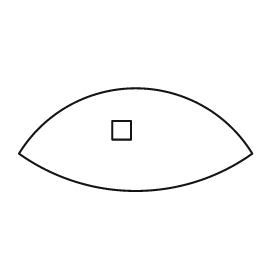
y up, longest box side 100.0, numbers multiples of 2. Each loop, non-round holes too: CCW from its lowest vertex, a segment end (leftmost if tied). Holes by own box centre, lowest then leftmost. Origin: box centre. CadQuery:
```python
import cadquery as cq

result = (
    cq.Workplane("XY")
    .moveTo(-50.0, -6.0)
    .threePointArc((0.0, -22.0), (50.0, -6.0))
    .threePointArc((0.0, 22.0), (-50.0, -6.0))
    .close()
    .moveTo(-10.0, 0.0)
    .lineTo(-2.0, 0.0)
    .lineTo(-2.0, 8.0)
    .lineTo(-10.0, 8.0)
    .close()
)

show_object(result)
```